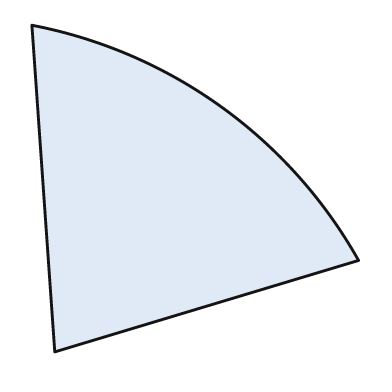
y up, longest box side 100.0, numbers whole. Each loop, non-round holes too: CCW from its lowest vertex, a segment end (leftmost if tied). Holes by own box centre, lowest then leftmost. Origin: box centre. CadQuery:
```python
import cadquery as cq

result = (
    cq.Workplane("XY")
    .moveTo(-43.0, -50.0)
    .lineTo(50.0, -22.0)
    .threePointArc((8.0, 25.0), (-50.0, 50.0))
    .close()
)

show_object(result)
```